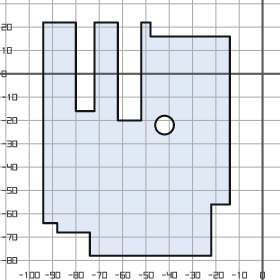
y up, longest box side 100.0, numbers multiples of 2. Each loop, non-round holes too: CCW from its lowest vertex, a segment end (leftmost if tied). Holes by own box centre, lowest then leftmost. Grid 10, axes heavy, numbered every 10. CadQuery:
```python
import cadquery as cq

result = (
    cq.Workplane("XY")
    .moveTo(-74.0, -78.0)
    .lineTo(-22.0, -78.0)
    .lineTo(-22.0, -56.0)
    .lineTo(-14.0, -56.0)
    .lineTo(-14.0, 16.0)
    .lineTo(-48.0, 16.0)
    .lineTo(-48.0, 22.0)
    .lineTo(-52.0, 22.0)
    .lineTo(-52.0, -20.0)
    .lineTo(-62.0, -20.0)
    .lineTo(-62.0, 22.0)
    .lineTo(-72.0, 22.0)
    .lineTo(-72.0, -16.0)
    .lineTo(-80.0, -16.0)
    .lineTo(-80.0, 22.0)
    .lineTo(-94.0, 22.0)
    .lineTo(-94.0, -64.0)
    .lineTo(-88.0, -64.0)
    .lineTo(-88.0, -68.0)
    .lineTo(-74.0, -68.0)
    .close()
    .moveTo(-42.0, -22.0)
    .circle(4.0)
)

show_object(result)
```